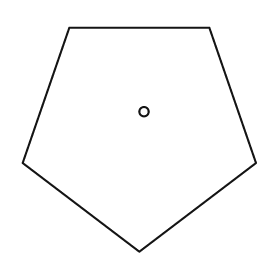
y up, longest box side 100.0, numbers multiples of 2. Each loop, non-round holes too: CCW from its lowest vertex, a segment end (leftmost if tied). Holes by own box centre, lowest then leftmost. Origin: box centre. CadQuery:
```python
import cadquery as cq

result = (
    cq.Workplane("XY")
    .moveTo(0.0, -48.0)
    .lineTo(50.0, -10.0)
    .lineTo(30.0, 48.0)
    .lineTo(-30.0, 48.0)
    .lineTo(-50.0, -10.0)
    .close()
    .moveTo(2.0, 12.0)
    .circle(2.0)
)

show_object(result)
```